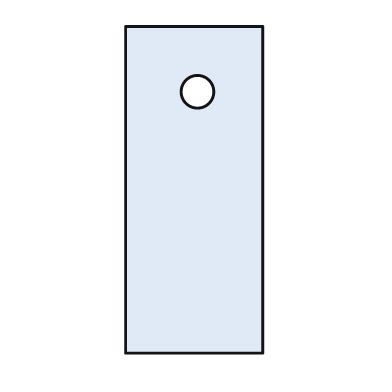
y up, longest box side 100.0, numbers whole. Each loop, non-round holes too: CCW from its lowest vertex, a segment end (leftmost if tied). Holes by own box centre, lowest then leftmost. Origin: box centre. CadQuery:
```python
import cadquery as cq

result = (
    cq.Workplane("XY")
    .moveTo(-21.0, -50.0)
    .lineTo(21.0, -50.0)
    .lineTo(21.0, 50.0)
    .lineTo(-21.0, 50.0)
    .close()
    .moveTo(1.0, 30.0)
    .circle(5.0)
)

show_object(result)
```